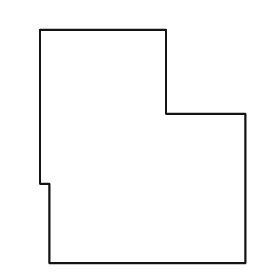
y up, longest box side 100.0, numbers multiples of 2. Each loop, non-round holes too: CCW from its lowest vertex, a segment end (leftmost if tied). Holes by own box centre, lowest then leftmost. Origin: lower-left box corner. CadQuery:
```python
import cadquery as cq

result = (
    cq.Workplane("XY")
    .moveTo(4.0, 0.0)
    .lineTo(88.0, 0.0)
    .lineTo(88.0, 64.0)
    .lineTo(54.0, 64.0)
    .lineTo(54.0, 100.0)
    .lineTo(0.0, 100.0)
    .lineTo(0.0, 34.0)
    .lineTo(4.0, 34.0)
    .close()
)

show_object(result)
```